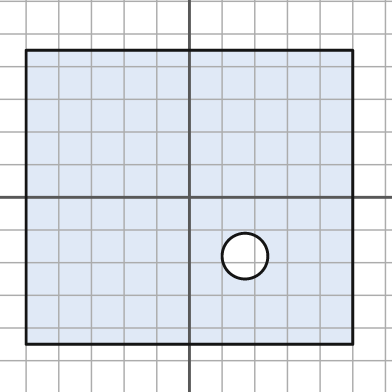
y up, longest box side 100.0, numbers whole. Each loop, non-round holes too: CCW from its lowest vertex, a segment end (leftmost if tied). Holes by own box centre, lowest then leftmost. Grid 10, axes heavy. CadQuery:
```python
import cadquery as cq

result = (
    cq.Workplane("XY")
    .moveTo(-50.0, -45.0)
    .lineTo(50.0, -45.0)
    .lineTo(50.0, 45.0)
    .lineTo(-50.0, 45.0)
    .close()
    .moveTo(17.0, -18.0)
    .circle(7.0)
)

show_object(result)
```